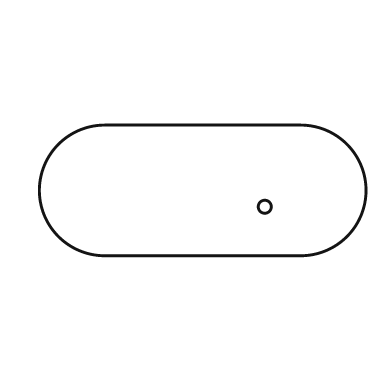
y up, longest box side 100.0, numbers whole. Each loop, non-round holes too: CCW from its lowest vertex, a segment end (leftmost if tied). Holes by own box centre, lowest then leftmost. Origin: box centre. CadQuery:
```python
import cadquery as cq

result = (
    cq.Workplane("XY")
    .moveTo(-30.0, -20.0)
    .lineTo(30.0, -20.0)
    .threePointArc((50.0, 0.0), (30.0, 20.0))
    .lineTo(-30.0, 20.0)
    .threePointArc((-50.0, 0.0), (-30.0, -20.0))
    .close()
    .moveTo(19.0, -5.0)
    .circle(2.0)
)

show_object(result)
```